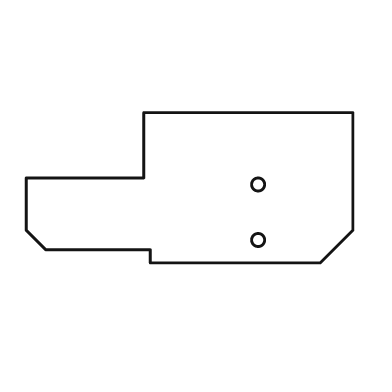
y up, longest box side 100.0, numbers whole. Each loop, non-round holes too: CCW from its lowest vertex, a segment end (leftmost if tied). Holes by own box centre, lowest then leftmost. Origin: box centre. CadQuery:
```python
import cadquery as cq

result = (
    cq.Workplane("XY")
    .moveTo(-12.0, -23.0)
    .lineTo(40.0, -23.0)
    .lineTo(50.0, -13.0)
    .lineTo(50.0, 23.0)
    .lineTo(-14.0, 23.0)
    .lineTo(-14.0, 3.0)
    .lineTo(-50.0, 3.0)
    .lineTo(-50.0, -13.0)
    .lineTo(-44.0, -19.0)
    .lineTo(-12.0, -19.0)
    .close()
    .moveTo(21.0, -16.0)
    .circle(2.0)
    .moveTo(21.0, 1.0)
    .circle(2.0)
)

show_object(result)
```